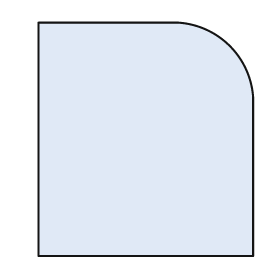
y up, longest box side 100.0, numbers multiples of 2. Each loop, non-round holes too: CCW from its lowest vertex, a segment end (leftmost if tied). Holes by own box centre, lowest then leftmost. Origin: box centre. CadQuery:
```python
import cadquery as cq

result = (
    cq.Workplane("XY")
    .moveTo(-46.0, -50.0)
    .lineTo(46.0, -50.0)
    .lineTo(46.0, 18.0)
    .threePointArc((36.0, 40.0), (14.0, 50.0))
    .lineTo(-46.0, 50.0)
    .close()
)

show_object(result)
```